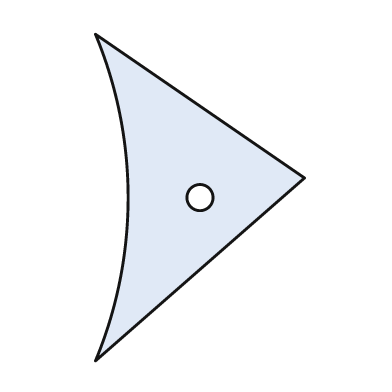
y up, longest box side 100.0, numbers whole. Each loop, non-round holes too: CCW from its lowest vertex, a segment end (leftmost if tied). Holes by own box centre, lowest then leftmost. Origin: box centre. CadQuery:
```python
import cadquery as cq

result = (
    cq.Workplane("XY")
    .moveTo(-32.0, -50.0)
    .lineTo(32.0, 6.0)
    .lineTo(-32.0, 50.0)
    .threePointArc((-22.0, 0.0), (-32.0, -50.0))
    .close()
    .moveTo(0.0, 0.0)
    .circle(4.0)
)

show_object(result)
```